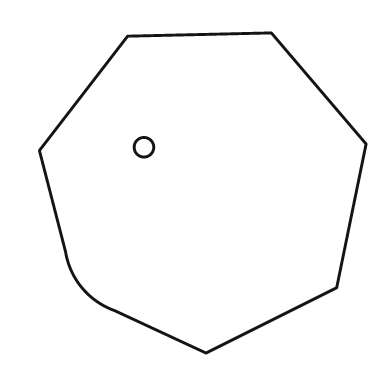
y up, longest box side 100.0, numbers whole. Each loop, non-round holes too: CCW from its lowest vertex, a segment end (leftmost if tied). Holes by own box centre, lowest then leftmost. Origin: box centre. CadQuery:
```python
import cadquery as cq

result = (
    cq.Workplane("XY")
    .moveTo(1.0, -49.0)
    .lineTo(41.0, -29.0)
    .lineTo(50.0, 15.0)
    .lineTo(21.0, 49.0)
    .lineTo(-23.0, 48.0)
    .lineTo(-50.0, 13.0)
    .lineTo(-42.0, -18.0)
    .threePointArc((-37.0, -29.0), (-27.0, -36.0))
    .close()
    .moveTo(-18.0, 14.0)
    .circle(3.0)
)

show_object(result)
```